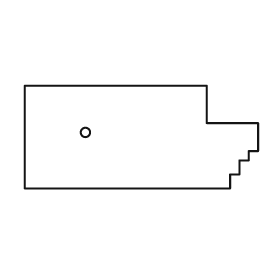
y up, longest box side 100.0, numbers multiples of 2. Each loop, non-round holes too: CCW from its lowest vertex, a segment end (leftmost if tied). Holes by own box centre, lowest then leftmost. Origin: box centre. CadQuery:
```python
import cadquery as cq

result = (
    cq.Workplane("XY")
    .moveTo(-50.0, -22.0)
    .lineTo(38.0, -22.0)
    .lineTo(38.0, -16.0)
    .lineTo(42.0, -16.0)
    .lineTo(42.0, -10.0)
    .lineTo(46.0, -10.0)
    .lineTo(46.0, -6.0)
    .lineTo(50.0, -6.0)
    .lineTo(50.0, 6.0)
    .lineTo(28.0, 6.0)
    .lineTo(28.0, 22.0)
    .lineTo(-50.0, 22.0)
    .close()
    .moveTo(-24.0, 2.0)
    .circle(2.0)
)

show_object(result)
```